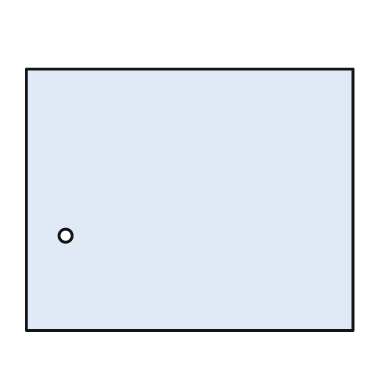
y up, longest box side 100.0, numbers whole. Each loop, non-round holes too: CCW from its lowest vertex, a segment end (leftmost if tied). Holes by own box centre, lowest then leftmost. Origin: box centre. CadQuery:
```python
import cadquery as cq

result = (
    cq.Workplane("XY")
    .moveTo(-50.0, -40.0)
    .lineTo(50.0, -40.0)
    .lineTo(50.0, 40.0)
    .lineTo(-50.0, 40.0)
    .close()
    .moveTo(-38.0, -11.0)
    .circle(2.0)
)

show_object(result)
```